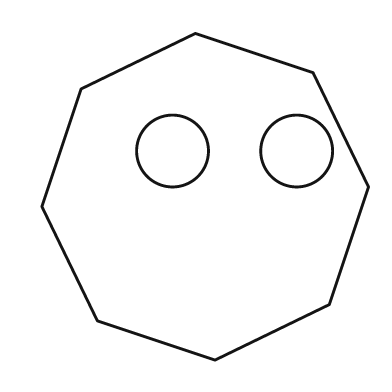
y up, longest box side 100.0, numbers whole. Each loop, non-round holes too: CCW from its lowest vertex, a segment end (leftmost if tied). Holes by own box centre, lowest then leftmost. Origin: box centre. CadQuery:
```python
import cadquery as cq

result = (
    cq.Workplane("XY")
    .moveTo(3.0, -50.0)
    .lineTo(38.0, -33.0)
    .lineTo(50.0, 3.0)
    .lineTo(33.0, 38.0)
    .lineTo(-3.0, 50.0)
    .lineTo(-38.0, 33.0)
    .lineTo(-50.0, -3.0)
    .lineTo(-33.0, -38.0)
    .close()
    .moveTo(-10.0, 14.0)
    .circle(11.0)
    .moveTo(28.0, 14.0)
    .circle(11.0)
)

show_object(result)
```